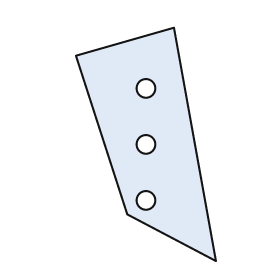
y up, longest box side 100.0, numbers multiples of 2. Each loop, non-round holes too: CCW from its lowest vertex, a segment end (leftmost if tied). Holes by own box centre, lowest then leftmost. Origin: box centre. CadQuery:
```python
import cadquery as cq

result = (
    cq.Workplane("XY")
    .moveTo(30.0, -50.0)
    .lineTo(12.0, 50.0)
    .lineTo(-30.0, 38.0)
    .lineTo(-8.0, -30.0)
    .close()
    .moveTo(0.0, -24.0)
    .circle(4.0)
    .moveTo(0.0, 0.0)
    .circle(4.0)
    .moveTo(0.0, 24.0)
    .circle(4.0)
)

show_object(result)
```